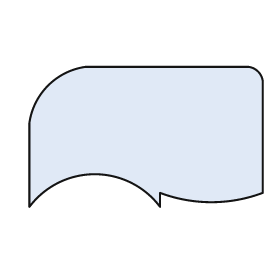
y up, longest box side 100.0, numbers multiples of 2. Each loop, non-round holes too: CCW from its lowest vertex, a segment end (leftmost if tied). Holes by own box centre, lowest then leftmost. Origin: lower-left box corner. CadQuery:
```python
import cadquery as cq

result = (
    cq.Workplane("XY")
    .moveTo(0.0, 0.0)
    .threePointArc((28.0, 14.0), (56.0, 0.0))
    .lineTo(56.0, 6.0)
    .threePointArc((78.0, 2.0), (100.0, 6.0))
    .lineTo(100.0, 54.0)
    .threePointArc((98.0, 58.0), (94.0, 60.0))
    .lineTo(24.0, 60.0)
    .threePointArc((8.0, 52.0), (0.0, 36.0))
    .close()
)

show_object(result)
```